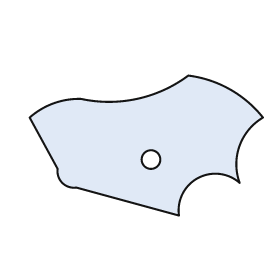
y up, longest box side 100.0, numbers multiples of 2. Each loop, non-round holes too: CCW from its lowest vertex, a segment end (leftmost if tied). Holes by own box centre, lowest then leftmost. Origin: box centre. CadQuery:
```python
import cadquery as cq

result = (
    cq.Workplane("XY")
    .moveTo(14.0, -30.0)
    .threePointArc((22.0, -14.0), (40.0, -16.0))
    .threePointArc((40.0, 0.0), (50.0, 12.0))
    .threePointArc((36.0, 24.0), (18.0, 30.0))
    .threePointArc((-4.0, 20.0), (-28.0, 20.0))
    .threePointArc((-40.0, 18.0), (-50.0, 12.0))
    .lineTo(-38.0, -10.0)
    .threePointArc((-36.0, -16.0), (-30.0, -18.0))
    .close()
    .moveTo(2.0, -6.0)
    .circle(4.0)
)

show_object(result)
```